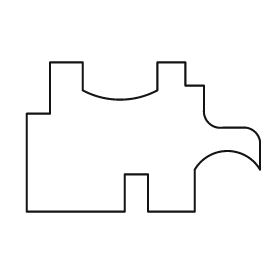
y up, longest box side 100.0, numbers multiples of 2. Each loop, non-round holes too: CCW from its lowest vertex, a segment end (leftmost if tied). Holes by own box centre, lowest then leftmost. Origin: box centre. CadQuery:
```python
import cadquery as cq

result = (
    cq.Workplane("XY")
    .moveTo(-50.0, -32.0)
    .lineTo(-8.0, -32.0)
    .lineTo(-8.0, -16.0)
    .lineTo(2.0, -16.0)
    .lineTo(2.0, -32.0)
    .lineTo(22.0, -32.0)
    .lineTo(22.0, -14.0)
    .threePointArc((36.0, -6.0), (50.0, -14.0))
    .lineTo(50.0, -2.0)
    .threePointArc((48.0, 2.0), (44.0, 4.0))
    .lineTo(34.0, 4.0)
    .threePointArc((28.0, 6.0), (26.0, 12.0))
    .lineTo(26.0, 22.0)
    .lineTo(18.0, 22.0)
    .lineTo(18.0, 32.0)
    .lineTo(6.0, 32.0)
    .lineTo(6.0, 20.0)
    .threePointArc((-10.0, 16.0), (-26.0, 20.0))
    .lineTo(-26.0, 32.0)
    .lineTo(-40.0, 32.0)
    .lineTo(-40.0, 10.0)
    .lineTo(-50.0, 10.0)
    .close()
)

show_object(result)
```